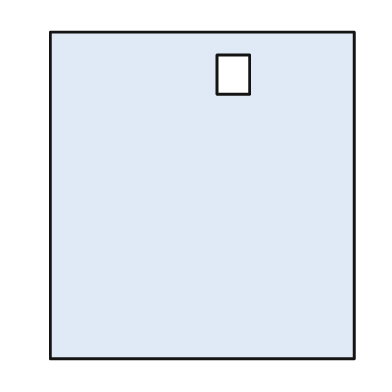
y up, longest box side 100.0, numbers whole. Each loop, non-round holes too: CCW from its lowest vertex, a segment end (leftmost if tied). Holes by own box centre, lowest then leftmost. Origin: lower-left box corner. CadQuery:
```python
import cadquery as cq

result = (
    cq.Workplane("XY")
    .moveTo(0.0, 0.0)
    .lineTo(93.0, 0.0)
    .lineTo(93.0, 100.0)
    .lineTo(0.0, 100.0)
    .close()
    .moveTo(51.0, 81.0)
    .lineTo(61.0, 81.0)
    .lineTo(61.0, 93.0)
    .lineTo(51.0, 93.0)
    .close()
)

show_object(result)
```